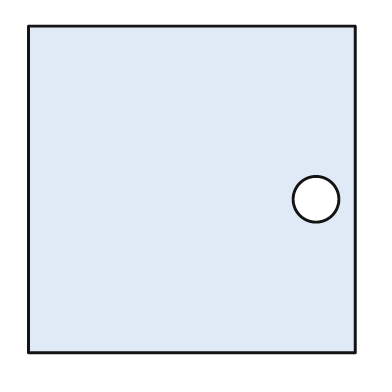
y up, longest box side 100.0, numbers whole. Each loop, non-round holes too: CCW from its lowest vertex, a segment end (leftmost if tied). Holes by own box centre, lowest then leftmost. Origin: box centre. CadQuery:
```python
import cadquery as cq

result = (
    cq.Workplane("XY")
    .moveTo(-50.0, -50.0)
    .lineTo(50.0, -50.0)
    .lineTo(50.0, 50.0)
    .lineTo(-50.0, 50.0)
    .close()
    .moveTo(38.0, -3.0)
    .circle(7.0)
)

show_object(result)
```